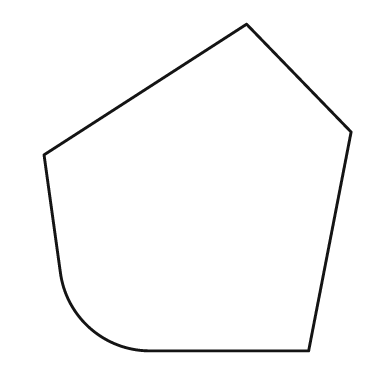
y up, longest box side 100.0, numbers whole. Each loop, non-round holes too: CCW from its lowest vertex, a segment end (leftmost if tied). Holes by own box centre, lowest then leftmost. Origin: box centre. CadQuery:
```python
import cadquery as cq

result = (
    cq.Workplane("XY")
    .moveTo(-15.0, -50.0)
    .lineTo(34.0, -50.0)
    .lineTo(47.0, 17.0)
    .lineTo(15.0, 50.0)
    .lineTo(-47.0, 10.0)
    .lineTo(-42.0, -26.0)
    .threePointArc((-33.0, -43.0), (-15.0, -50.0))
    .close()
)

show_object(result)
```